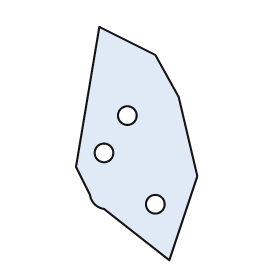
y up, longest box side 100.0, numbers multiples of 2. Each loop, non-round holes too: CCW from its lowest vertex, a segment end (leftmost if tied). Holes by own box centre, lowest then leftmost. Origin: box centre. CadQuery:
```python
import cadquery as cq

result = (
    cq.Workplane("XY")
    .moveTo(14.0, -50.0)
    .lineTo(26.0, -14.0)
    .lineTo(18.0, 20.0)
    .lineTo(8.0, 38.0)
    .lineTo(-16.0, 50.0)
    .lineTo(-26.0, -10.0)
    .lineTo(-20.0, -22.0)
    .threePointArc((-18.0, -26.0), (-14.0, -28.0))
    .close()
    .moveTo(8.0, -26.0)
    .circle(4.0)
    .moveTo(-14.0, -4.0)
    .circle(4.0)
    .moveTo(-4.0, 12.0)
    .circle(4.0)
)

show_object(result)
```